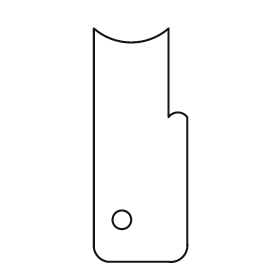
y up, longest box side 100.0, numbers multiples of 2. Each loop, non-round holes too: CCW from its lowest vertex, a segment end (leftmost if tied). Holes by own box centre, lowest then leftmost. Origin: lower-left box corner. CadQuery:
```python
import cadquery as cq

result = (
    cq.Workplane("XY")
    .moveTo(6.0, 0.0)
    .lineTo(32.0, 0.0)
    .threePointArc((38.0, 2.0), (40.0, 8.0))
    .lineTo(40.0, 62.0)
    .threePointArc((36.0, 64.0), (32.0, 62.0))
    .lineTo(32.0, 100.0)
    .threePointArc((16.0, 94.0), (0.0, 100.0))
    .lineTo(0.0, 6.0)
    .threePointArc((2.0, 2.0), (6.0, 0.0))
    .close()
    .moveTo(12.0, 18.0)
    .circle(4.0)
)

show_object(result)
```